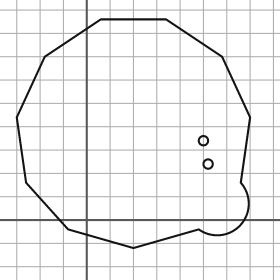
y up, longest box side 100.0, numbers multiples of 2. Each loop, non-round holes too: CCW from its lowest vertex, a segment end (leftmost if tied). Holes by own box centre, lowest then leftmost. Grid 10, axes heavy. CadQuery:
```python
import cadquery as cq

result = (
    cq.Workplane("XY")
    .moveTo(20.0, -12.0)
    .lineTo(48.0, -4.0)
    .threePointArc((66.0, -2.0), (66.0, 16.0))
    .lineTo(70.0, 44.0)
    .lineTo(58.0, 70.0)
    .lineTo(34.0, 86.0)
    .lineTo(6.0, 86.0)
    .lineTo(-18.0, 70.0)
    .lineTo(-30.0, 44.0)
    .lineTo(-26.0, 16.0)
    .lineTo(-8.0, -4.0)
    .close()
    .moveTo(52.0, 24.0)
    .circle(2.0)
    .moveTo(50.0, 34.0)
    .circle(2.0)
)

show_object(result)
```